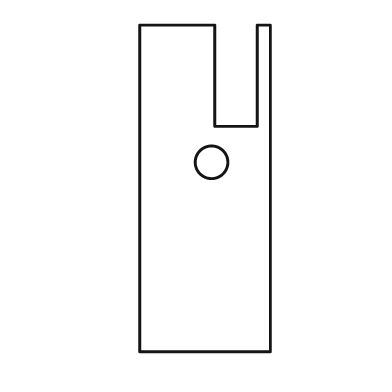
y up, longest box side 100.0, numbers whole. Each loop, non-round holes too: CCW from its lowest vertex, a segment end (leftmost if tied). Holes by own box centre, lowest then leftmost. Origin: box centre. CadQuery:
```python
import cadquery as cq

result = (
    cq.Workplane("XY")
    .moveTo(-20.0, -50.0)
    .lineTo(20.0, -50.0)
    .lineTo(20.0, 50.0)
    .lineTo(16.0, 50.0)
    .lineTo(16.0, 19.0)
    .lineTo(3.0, 19.0)
    .lineTo(3.0, 50.0)
    .lineTo(-20.0, 50.0)
    .close()
    .moveTo(2.0, 8.0)
    .circle(5.0)
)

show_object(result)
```